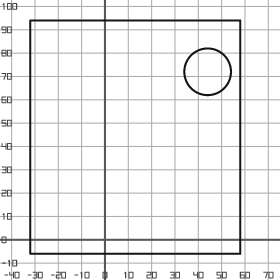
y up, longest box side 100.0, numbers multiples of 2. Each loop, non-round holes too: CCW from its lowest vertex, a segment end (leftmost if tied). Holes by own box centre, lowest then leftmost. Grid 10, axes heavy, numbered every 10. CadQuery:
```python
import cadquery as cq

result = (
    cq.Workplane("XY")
    .moveTo(-32.0, -6.0)
    .lineTo(58.0, -6.0)
    .lineTo(58.0, 94.0)
    .lineTo(-32.0, 94.0)
    .close()
    .moveTo(44.0, 72.0)
    .circle(10.0)
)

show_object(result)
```